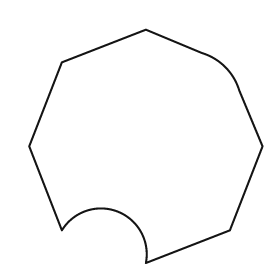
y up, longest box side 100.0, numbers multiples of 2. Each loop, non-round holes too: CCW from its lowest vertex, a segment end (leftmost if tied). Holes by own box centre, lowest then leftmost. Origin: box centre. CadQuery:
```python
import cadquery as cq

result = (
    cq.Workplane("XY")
    .moveTo(0.0, -50.0)
    .lineTo(36.0, -36.0)
    .lineTo(50.0, 0.0)
    .lineTo(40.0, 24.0)
    .threePointArc((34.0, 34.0), (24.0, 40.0))
    .lineTo(0.0, 50.0)
    .lineTo(-36.0, 36.0)
    .lineTo(-50.0, 0.0)
    .lineTo(-36.0, -36.0)
    .threePointArc((-12.0, -28.0), (0.0, -50.0))
    .close()
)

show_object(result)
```